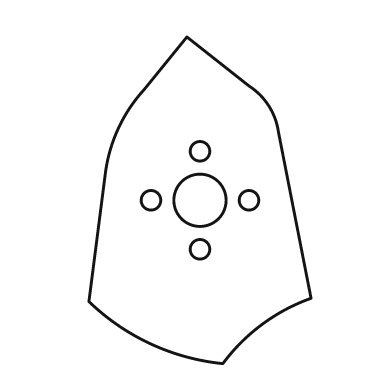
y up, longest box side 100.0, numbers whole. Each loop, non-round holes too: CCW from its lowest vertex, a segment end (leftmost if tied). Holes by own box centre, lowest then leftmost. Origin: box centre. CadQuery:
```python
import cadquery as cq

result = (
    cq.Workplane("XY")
    .moveTo(7.0, -50.0)
    .threePointArc((19.0, -38.0), (34.0, -30.0))
    .lineTo(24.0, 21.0)
    .threePointArc((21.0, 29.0), (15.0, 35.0))
    .lineTo(-4.0, 50.0)
    .lineTo(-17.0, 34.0)
    .threePointArc((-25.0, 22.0), (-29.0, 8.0))
    .lineTo(-34.0, -31.0)
    .threePointArc((-15.0, -44.0), (7.0, -50.0))
    .close()
    .moveTo(0.0, -15.0)
    .circle(3.0)
    .moveTo(-15.0, 0.0)
    .circle(3.0)
    .moveTo(0.0, 0.0)
    .circle(8.0)
    .moveTo(15.0, 0.0)
    .circle(3.0)
    .moveTo(0.0, 15.0)
    .circle(3.0)
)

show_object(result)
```